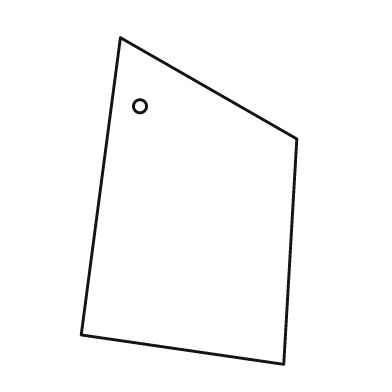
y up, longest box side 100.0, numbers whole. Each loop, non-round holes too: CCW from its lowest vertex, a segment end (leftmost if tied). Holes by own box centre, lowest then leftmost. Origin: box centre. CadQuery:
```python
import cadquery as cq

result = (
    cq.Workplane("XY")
    .moveTo(29.0, -50.0)
    .lineTo(33.0, 19.0)
    .lineTo(-21.0, 50.0)
    .lineTo(-33.0, -41.0)
    .close()
    .moveTo(-15.0, 29.0)
    .circle(2.0)
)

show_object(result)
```